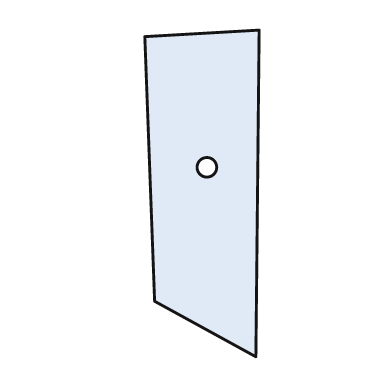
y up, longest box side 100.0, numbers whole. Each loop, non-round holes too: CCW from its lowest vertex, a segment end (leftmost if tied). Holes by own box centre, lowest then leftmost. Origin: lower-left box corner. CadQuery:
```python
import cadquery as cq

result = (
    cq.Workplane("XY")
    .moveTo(34.0, 0.0)
    .lineTo(35.0, 100.0)
    .lineTo(0.0, 98.0)
    .lineTo(3.0, 17.0)
    .close()
    .moveTo(19.0, 58.0)
    .circle(3.0)
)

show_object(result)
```